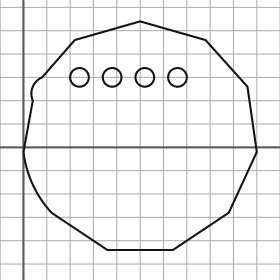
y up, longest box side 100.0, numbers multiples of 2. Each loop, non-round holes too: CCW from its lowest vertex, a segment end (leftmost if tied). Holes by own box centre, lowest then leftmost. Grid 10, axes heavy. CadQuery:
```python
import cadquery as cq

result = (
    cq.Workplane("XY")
    .moveTo(36.0, -44.0)
    .lineTo(64.0, -44.0)
    .lineTo(88.0, -28.0)
    .lineTo(100.0, -2.0)
    .lineTo(96.0, 26.0)
    .lineTo(78.0, 46.0)
    .lineTo(50.0, 54.0)
    .lineTo(22.0, 46.0)
    .lineTo(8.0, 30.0)
    .threePointArc((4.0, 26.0), (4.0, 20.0))
    .lineTo(0.0, -2.0)
    .threePointArc((4.0, -16.0), (12.0, -28.0))
    .close()
    .moveTo(24.0, 30.0)
    .circle(4.0)
    .moveTo(38.0, 30.0)
    .circle(4.0)
    .moveTo(52.0, 30.0)
    .circle(4.0)
    .moveTo(66.0, 30.0)
    .circle(4.0)
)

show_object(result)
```